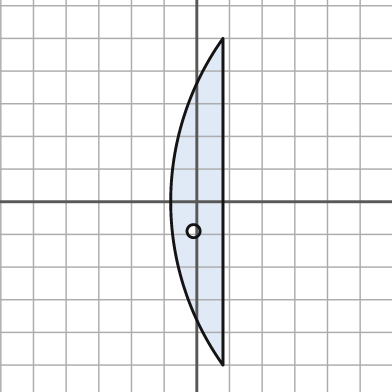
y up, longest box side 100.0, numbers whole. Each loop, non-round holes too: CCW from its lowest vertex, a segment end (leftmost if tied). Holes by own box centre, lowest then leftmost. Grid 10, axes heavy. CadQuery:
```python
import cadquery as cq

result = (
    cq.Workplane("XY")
    .moveTo(8.0, -50.0)
    .lineTo(8.0, 50.0)
    .threePointArc((-8.0, 0.0), (8.0, -50.0))
    .close()
    .moveTo(-1.0, -9.0)
    .circle(2.0)
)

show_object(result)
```